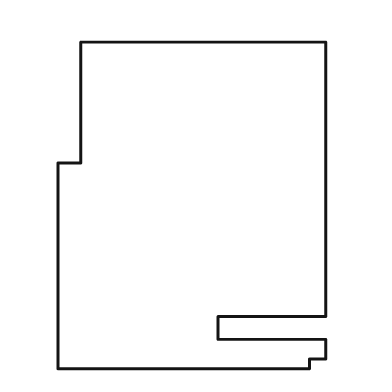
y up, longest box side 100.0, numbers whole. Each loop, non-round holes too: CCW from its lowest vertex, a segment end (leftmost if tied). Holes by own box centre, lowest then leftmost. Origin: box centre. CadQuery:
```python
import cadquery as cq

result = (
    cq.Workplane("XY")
    .moveTo(-41.0, -50.0)
    .lineTo(36.0, -50.0)
    .lineTo(36.0, -47.0)
    .lineTo(41.0, -47.0)
    .lineTo(41.0, -41.0)
    .lineTo(8.0, -41.0)
    .lineTo(8.0, -34.0)
    .lineTo(41.0, -34.0)
    .lineTo(41.0, 50.0)
    .lineTo(-34.0, 50.0)
    .lineTo(-34.0, 13.0)
    .lineTo(-41.0, 13.0)
    .close()
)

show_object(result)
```